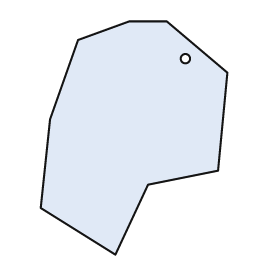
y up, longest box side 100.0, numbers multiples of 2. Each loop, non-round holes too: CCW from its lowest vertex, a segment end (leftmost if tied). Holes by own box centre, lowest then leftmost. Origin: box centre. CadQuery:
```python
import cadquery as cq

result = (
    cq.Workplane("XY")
    .moveTo(-8.0, -50.0)
    .lineTo(6.0, -20.0)
    .lineTo(36.0, -14.0)
    .lineTo(40.0, 28.0)
    .lineTo(14.0, 50.0)
    .lineTo(-2.0, 50.0)
    .lineTo(-24.0, 42.0)
    .lineTo(-36.0, 8.0)
    .lineTo(-40.0, -30.0)
    .close()
    .moveTo(22.0, 34.0)
    .circle(2.0)
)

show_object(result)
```